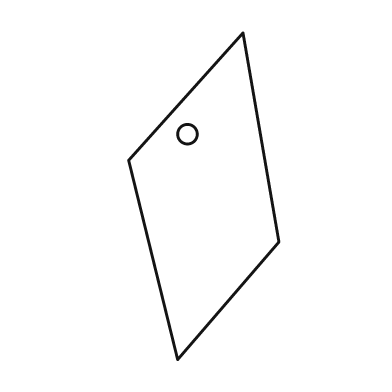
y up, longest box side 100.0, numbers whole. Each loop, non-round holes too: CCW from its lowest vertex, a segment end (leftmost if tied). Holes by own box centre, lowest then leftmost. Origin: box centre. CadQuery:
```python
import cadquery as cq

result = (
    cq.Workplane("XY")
    .moveTo(-8.0, -50.0)
    .lineTo(23.0, -14.0)
    .lineTo(12.0, 50.0)
    .lineTo(-23.0, 11.0)
    .close()
    .moveTo(-5.0, 19.0)
    .circle(3.0)
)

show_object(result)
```